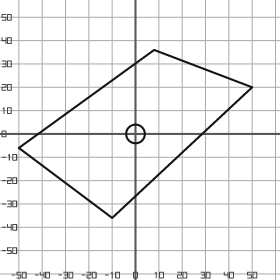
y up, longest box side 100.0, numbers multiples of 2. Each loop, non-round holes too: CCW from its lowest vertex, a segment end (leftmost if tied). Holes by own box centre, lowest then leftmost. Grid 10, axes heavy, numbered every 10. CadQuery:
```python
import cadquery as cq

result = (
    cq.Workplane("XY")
    .moveTo(-10.0, -36.0)
    .lineTo(50.0, 20.0)
    .lineTo(8.0, 36.0)
    .lineTo(-50.0, -6.0)
    .close()
    .moveTo(0.0, 0.0)
    .circle(4.0)
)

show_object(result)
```